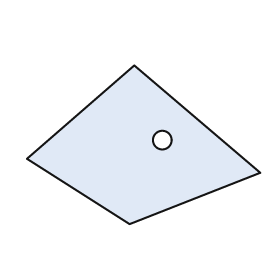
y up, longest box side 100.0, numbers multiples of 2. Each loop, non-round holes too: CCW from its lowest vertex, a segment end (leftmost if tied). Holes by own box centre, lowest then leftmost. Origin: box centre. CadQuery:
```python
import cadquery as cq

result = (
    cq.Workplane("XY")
    .moveTo(-6.0, -34.0)
    .lineTo(50.0, -12.0)
    .lineTo(-4.0, 34.0)
    .lineTo(-50.0, -6.0)
    .close()
    .moveTo(8.0, 2.0)
    .circle(4.0)
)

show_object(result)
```